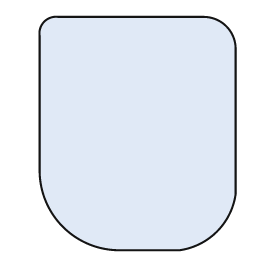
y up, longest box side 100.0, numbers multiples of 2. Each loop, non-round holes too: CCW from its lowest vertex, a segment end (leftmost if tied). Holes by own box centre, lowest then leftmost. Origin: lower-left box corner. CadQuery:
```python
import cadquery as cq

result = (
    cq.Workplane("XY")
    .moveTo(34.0, 0.0)
    .lineTo(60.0, 0.0)
    .threePointArc((76.0, 8.0), (84.0, 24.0))
    .lineTo(84.0, 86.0)
    .threePointArc((80.0, 96.0), (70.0, 100.0))
    .lineTo(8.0, 100.0)
    .threePointArc((2.0, 98.0), (0.0, 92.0))
    .lineTo(0.0, 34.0)
    .threePointArc((10.0, 10.0), (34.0, 0.0))
    .close()
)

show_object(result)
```